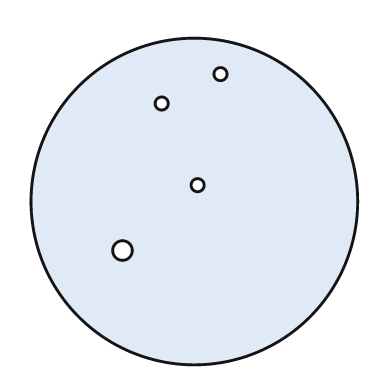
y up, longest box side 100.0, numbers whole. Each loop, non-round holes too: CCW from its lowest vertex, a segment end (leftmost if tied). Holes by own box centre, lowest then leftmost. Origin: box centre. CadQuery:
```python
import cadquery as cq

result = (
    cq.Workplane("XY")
    .moveTo(0.0, 0.0)
    .circle(50.0)
    .moveTo(-22.0, -15.0)
    .circle(3.0)
    .moveTo(1.0, 5.0)
    .circle(2.0)
    .moveTo(-10.0, 30.0)
    .circle(2.0)
    .moveTo(8.0, 39.0)
    .circle(2.0)
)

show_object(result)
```